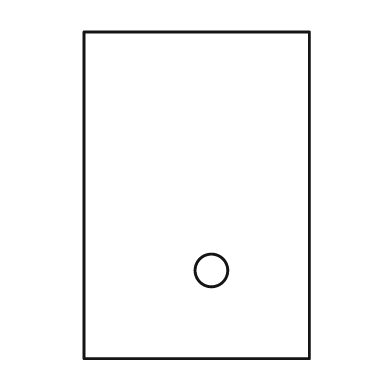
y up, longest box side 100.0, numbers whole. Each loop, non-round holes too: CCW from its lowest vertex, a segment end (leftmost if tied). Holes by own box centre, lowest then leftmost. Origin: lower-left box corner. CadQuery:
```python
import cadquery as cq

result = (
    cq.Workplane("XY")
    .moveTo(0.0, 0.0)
    .lineTo(69.0, 0.0)
    .lineTo(69.0, 100.0)
    .lineTo(0.0, 100.0)
    .close()
    .moveTo(39.0, 27.0)
    .circle(5.0)
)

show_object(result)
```